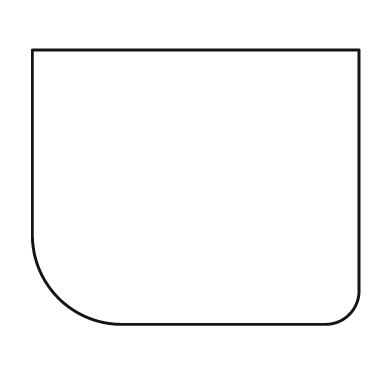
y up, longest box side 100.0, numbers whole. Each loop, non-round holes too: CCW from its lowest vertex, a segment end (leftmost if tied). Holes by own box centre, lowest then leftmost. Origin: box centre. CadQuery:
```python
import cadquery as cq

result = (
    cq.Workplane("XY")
    .moveTo(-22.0, -42.0)
    .lineTo(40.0, -42.0)
    .threePointArc((47.0, -39.0), (50.0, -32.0))
    .lineTo(50.0, 42.0)
    .lineTo(-50.0, 42.0)
    .lineTo(-50.0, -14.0)
    .threePointArc((-42.0, -34.0), (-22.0, -42.0))
    .close()
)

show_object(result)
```